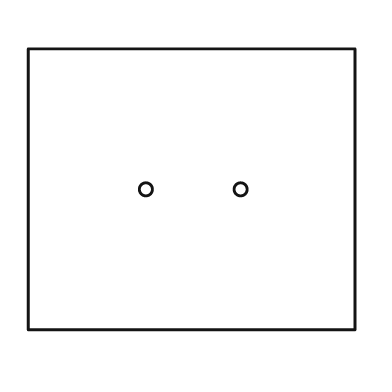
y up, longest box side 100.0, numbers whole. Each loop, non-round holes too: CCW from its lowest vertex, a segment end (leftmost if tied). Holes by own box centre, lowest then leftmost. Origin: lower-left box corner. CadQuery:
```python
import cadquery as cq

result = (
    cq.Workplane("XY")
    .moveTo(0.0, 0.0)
    .lineTo(100.0, 0.0)
    .lineTo(100.0, 86.0)
    .lineTo(0.0, 86.0)
    .close()
    .moveTo(36.0, 43.0)
    .circle(2.0)
    .moveTo(65.0, 43.0)
    .circle(2.0)
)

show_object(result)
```